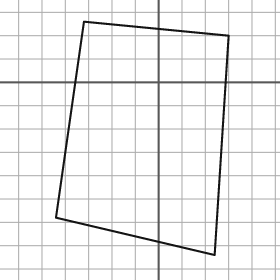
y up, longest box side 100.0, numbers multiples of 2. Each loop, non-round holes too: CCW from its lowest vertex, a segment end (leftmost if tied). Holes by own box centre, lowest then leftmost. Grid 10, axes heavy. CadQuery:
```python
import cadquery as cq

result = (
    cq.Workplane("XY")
    .moveTo(24.0, -74.0)
    .lineTo(30.0, 20.0)
    .lineTo(-32.0, 26.0)
    .lineTo(-44.0, -58.0)
    .close()
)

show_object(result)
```